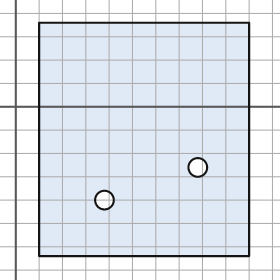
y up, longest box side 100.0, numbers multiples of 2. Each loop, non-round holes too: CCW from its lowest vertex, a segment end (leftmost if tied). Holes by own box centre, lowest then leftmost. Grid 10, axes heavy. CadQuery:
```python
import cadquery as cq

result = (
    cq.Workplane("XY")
    .moveTo(10.0, -64.0)
    .lineTo(100.0, -64.0)
    .lineTo(100.0, 36.0)
    .lineTo(10.0, 36.0)
    .close()
    .moveTo(38.0, -40.0)
    .circle(4.0)
    .moveTo(78.0, -26.0)
    .circle(4.0)
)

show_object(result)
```